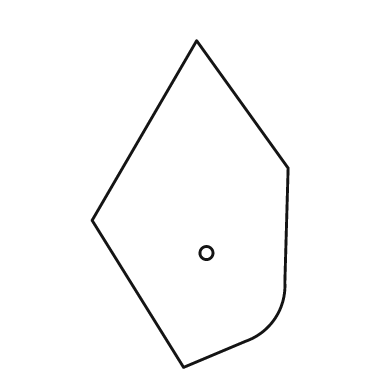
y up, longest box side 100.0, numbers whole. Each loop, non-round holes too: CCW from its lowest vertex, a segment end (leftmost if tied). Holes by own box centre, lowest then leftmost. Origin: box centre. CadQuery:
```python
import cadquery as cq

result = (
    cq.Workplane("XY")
    .moveTo(-2.0, -50.0)
    .lineTo(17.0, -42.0)
    .threePointArc((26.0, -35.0), (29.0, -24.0))
    .lineTo(30.0, 11.0)
    .lineTo(2.0, 50.0)
    .lineTo(-30.0, -5.0)
    .close()
    .moveTo(5.0, -15.0)
    .circle(2.0)
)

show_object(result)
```